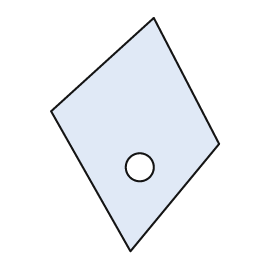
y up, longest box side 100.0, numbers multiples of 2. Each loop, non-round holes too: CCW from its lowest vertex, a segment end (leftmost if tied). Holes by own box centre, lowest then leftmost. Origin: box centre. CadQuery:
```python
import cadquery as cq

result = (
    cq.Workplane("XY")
    .moveTo(-2.0, -50.0)
    .lineTo(36.0, -4.0)
    .lineTo(8.0, 50.0)
    .lineTo(-36.0, 10.0)
    .close()
    .moveTo(2.0, -14.0)
    .circle(6.0)
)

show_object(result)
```